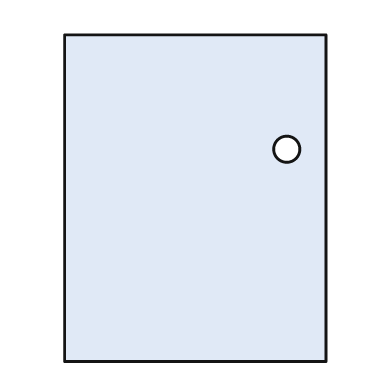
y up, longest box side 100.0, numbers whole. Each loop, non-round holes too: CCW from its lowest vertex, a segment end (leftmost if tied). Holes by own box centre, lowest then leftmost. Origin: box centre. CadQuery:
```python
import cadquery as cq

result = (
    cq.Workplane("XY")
    .moveTo(-40.0, -50.0)
    .lineTo(40.0, -50.0)
    .lineTo(40.0, 50.0)
    .lineTo(-40.0, 50.0)
    .close()
    .moveTo(28.0, 15.0)
    .circle(4.0)
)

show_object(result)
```